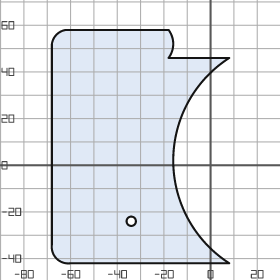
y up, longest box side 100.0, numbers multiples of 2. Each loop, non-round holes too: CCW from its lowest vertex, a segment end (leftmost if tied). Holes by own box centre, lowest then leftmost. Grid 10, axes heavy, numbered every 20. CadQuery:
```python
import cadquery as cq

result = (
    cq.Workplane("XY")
    .moveTo(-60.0, -42.0)
    .lineTo(8.0, -42.0)
    .threePointArc((-16.0, 2.0), (8.0, 46.0))
    .lineTo(-18.0, 46.0)
    .threePointArc((-16.0, 52.0), (-18.0, 58.0))
    .lineTo(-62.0, 58.0)
    .threePointArc((-66.0, 56.0), (-68.0, 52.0))
    .lineTo(-68.0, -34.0)
    .threePointArc((-66.0, -40.0), (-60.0, -42.0))
    .close()
    .moveTo(-34.0, -24.0)
    .circle(2.0)
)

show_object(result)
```